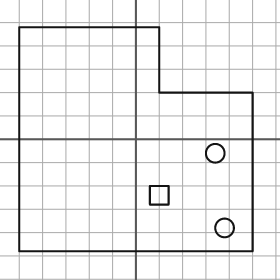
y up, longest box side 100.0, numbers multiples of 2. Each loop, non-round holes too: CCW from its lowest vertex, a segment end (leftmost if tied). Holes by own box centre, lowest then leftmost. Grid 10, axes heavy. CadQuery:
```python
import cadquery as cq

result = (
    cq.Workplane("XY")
    .moveTo(-50.0, -48.0)
    .lineTo(50.0, -48.0)
    .lineTo(50.0, 20.0)
    .lineTo(10.0, 20.0)
    .lineTo(10.0, 48.0)
    .lineTo(-50.0, 48.0)
    .close()
    .moveTo(38.0, -38.0)
    .circle(4.0)
    .moveTo(6.0, -28.0)
    .lineTo(14.0, -28.0)
    .lineTo(14.0, -20.0)
    .lineTo(6.0, -20.0)
    .close()
    .moveTo(34.0, -6.0)
    .circle(4.0)
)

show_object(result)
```